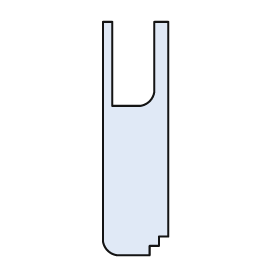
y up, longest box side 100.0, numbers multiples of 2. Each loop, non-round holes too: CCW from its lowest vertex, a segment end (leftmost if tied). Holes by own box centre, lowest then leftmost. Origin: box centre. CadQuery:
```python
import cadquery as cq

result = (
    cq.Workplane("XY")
    .moveTo(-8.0, -50.0)
    .lineTo(6.0, -50.0)
    .lineTo(6.0, -46.0)
    .lineTo(10.0, -46.0)
    .lineTo(10.0, -42.0)
    .lineTo(14.0, -42.0)
    .lineTo(14.0, 50.0)
    .lineTo(8.0, 50.0)
    .lineTo(8.0, 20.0)
    .threePointArc((6.0, 16.0), (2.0, 14.0))
    .lineTo(-10.0, 14.0)
    .lineTo(-10.0, 50.0)
    .lineTo(-14.0, 50.0)
    .lineTo(-14.0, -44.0)
    .threePointArc((-12.0, -48.0), (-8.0, -50.0))
    .close()
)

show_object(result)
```